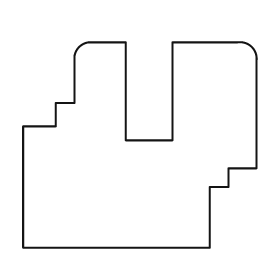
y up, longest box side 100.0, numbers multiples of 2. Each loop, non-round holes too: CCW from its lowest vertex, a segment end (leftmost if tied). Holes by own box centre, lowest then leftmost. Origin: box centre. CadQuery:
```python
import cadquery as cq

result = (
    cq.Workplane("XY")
    .moveTo(-50.0, -44.0)
    .lineTo(30.0, -44.0)
    .lineTo(30.0, -18.0)
    .lineTo(38.0, -18.0)
    .lineTo(38.0, -10.0)
    .lineTo(50.0, -10.0)
    .lineTo(50.0, 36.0)
    .threePointArc((48.0, 42.0), (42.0, 44.0))
    .lineTo(14.0, 44.0)
    .lineTo(14.0, 2.0)
    .lineTo(-6.0, 2.0)
    .lineTo(-6.0, 44.0)
    .lineTo(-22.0, 44.0)
    .threePointArc((-26.0, 42.0), (-28.0, 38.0))
    .lineTo(-28.0, 18.0)
    .lineTo(-36.0, 18.0)
    .lineTo(-36.0, 8.0)
    .lineTo(-50.0, 8.0)
    .close()
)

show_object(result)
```